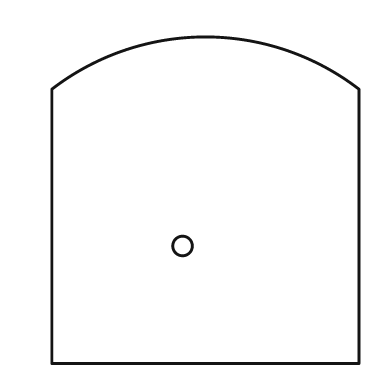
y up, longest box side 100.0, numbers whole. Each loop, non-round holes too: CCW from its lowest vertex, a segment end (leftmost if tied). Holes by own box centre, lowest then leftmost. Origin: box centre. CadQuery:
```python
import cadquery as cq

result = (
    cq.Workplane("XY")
    .moveTo(-47.0, -50.0)
    .lineTo(47.0, -50.0)
    .lineTo(47.0, 34.0)
    .threePointArc((0.0, 50.0), (-47.0, 34.0))
    .close()
    .moveTo(-7.0, -14.0)
    .circle(3.0)
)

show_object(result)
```